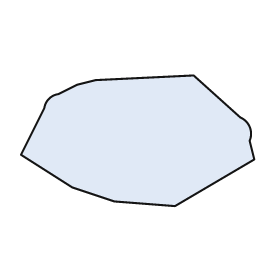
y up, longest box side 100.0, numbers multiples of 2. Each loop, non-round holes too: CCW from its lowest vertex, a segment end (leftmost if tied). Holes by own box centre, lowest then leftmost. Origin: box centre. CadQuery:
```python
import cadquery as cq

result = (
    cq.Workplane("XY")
    .moveTo(16.0, -28.0)
    .lineTo(50.0, -8.0)
    .lineTo(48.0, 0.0)
    .threePointArc((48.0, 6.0), (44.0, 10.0))
    .lineTo(24.0, 28.0)
    .lineTo(-18.0, 26.0)
    .lineTo(-26.0, 24.0)
    .lineTo(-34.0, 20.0)
    .threePointArc((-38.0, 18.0), (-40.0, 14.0))
    .lineTo(-50.0, -6.0)
    .lineTo(-28.0, -20.0)
    .lineTo(-10.0, -26.0)
    .close()
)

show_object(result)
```